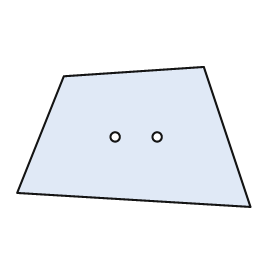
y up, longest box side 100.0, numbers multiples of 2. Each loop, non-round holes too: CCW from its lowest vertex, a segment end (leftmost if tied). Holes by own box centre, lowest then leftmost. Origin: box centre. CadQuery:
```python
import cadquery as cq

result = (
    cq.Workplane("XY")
    .moveTo(50.0, -30.0)
    .lineTo(30.0, 30.0)
    .lineTo(-30.0, 26.0)
    .lineTo(-50.0, -24.0)
    .close()
    .moveTo(-8.0, 0.0)
    .circle(2.0)
    .moveTo(10.0, 0.0)
    .circle(2.0)
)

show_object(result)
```